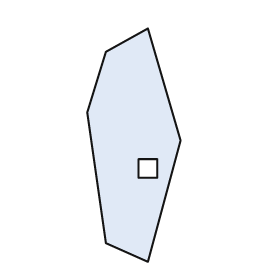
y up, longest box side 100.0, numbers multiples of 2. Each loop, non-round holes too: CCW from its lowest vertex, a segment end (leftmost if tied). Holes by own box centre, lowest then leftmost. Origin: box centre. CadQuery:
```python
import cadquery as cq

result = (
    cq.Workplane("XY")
    .moveTo(6.0, -50.0)
    .lineTo(20.0, 2.0)
    .lineTo(6.0, 50.0)
    .lineTo(-12.0, 40.0)
    .lineTo(-20.0, 14.0)
    .lineTo(-12.0, -42.0)
    .close()
    .moveTo(2.0, -14.0)
    .lineTo(10.0, -14.0)
    .lineTo(10.0, -6.0)
    .lineTo(2.0, -6.0)
    .close()
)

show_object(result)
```